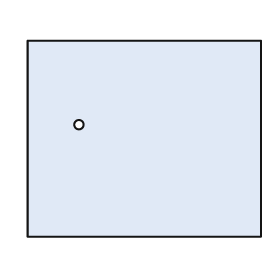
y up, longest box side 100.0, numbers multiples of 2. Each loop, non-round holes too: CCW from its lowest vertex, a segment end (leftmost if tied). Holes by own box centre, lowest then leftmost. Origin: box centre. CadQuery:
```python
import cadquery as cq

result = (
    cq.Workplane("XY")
    .moveTo(-50.0, -42.0)
    .lineTo(50.0, -42.0)
    .lineTo(50.0, 42.0)
    .lineTo(-50.0, 42.0)
    .close()
    .moveTo(-28.0, 6.0)
    .circle(2.0)
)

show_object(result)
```